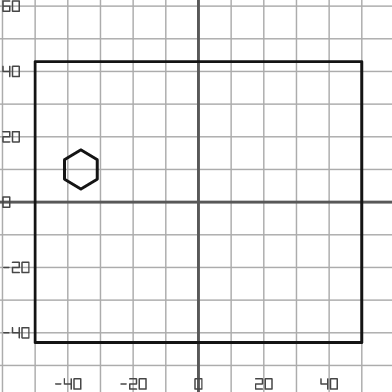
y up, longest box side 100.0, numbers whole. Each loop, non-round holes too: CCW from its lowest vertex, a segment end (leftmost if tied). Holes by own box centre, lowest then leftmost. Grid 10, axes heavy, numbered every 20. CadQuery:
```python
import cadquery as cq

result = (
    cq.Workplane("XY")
    .moveTo(-50.0, -43.0)
    .lineTo(50.0, -43.0)
    .lineTo(50.0, 43.0)
    .lineTo(-50.0, 43.0)
    .close()
    .moveTo(-36.0, 4.0)
    .lineTo(-31.0, 7.0)
    .lineTo(-31.0, 13.0)
    .lineTo(-36.0, 16.0)
    .lineTo(-41.0, 13.0)
    .lineTo(-41.0, 7.0)
    .close()
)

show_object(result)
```